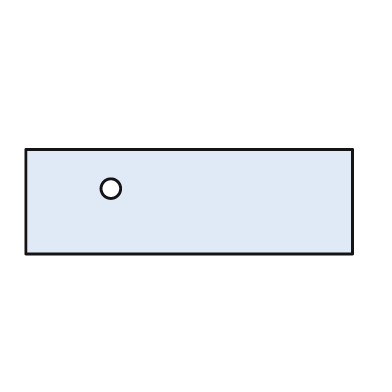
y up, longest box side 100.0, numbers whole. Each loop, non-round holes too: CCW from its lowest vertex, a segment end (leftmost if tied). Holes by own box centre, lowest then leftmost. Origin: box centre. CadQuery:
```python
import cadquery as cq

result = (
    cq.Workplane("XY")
    .moveTo(-50.0, -16.0)
    .lineTo(50.0, -16.0)
    .lineTo(50.0, 16.0)
    .lineTo(-50.0, 16.0)
    .close()
    .moveTo(-24.0, 4.0)
    .circle(3.0)
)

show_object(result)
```